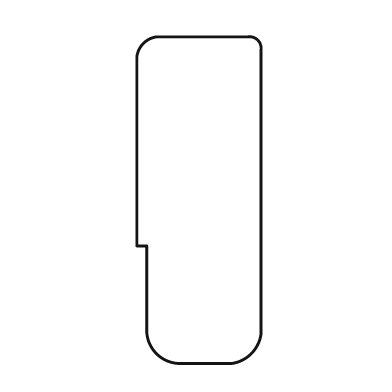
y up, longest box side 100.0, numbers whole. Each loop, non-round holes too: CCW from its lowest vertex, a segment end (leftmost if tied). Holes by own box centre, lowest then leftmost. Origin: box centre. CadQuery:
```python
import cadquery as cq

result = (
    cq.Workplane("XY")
    .moveTo(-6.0, -50.0)
    .lineTo(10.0, -50.0)
    .threePointArc((16.0, -47.0), (19.0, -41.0))
    .lineTo(19.0, 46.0)
    .threePointArc((18.0, 49.0), (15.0, 50.0))
    .lineTo(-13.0, 50.0)
    .threePointArc((-17.0, 48.0), (-19.0, 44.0))
    .lineTo(-19.0, -14.0)
    .lineTo(-16.0, -14.0)
    .lineTo(-16.0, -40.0)
    .threePointArc((-13.0, -47.0), (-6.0, -50.0))
    .close()
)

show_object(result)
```